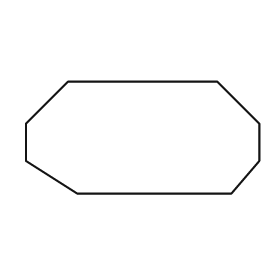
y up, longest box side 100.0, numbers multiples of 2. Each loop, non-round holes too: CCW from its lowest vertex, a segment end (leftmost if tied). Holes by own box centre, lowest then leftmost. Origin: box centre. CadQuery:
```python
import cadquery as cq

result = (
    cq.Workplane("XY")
    .moveTo(-28.0, -24.0)
    .lineTo(38.0, -24.0)
    .lineTo(50.0, -10.0)
    .lineTo(50.0, 6.0)
    .lineTo(32.0, 24.0)
    .lineTo(-32.0, 24.0)
    .lineTo(-50.0, 6.0)
    .lineTo(-50.0, -10.0)
    .close()
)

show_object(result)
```